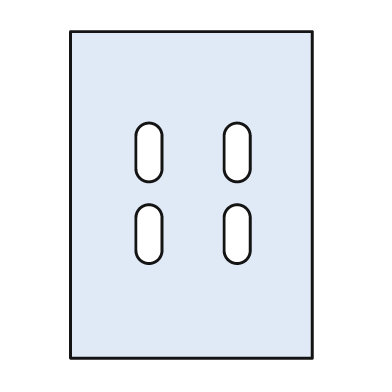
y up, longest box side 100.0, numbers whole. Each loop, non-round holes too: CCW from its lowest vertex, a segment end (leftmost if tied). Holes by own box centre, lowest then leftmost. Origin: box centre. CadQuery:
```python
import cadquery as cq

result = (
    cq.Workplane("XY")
    .moveTo(-37.0, -50.0)
    .lineTo(37.0, -50.0)
    .lineTo(37.0, 50.0)
    .lineTo(-37.0, 50.0)
    .close()
    .moveTo(-17.0, -17.0)
    .threePointArc((-13.0, -21.0), (-9.0, -17.0))
    .lineTo(-9.0, -7.0)
    .threePointArc((-13.0, -3.0), (-17.0, -7.0))
    .close()
    .moveTo(10.0, -17.0)
    .threePointArc((14.0, -21.0), (18.0, -17.0))
    .lineTo(18.0, -7.0)
    .threePointArc((14.0, -3.0), (10.0, -7.0))
    .close()
    .moveTo(-17.0, 8.0)
    .threePointArc((-13.0, 4.0), (-9.0, 8.0))
    .lineTo(-9.0, 18.0)
    .threePointArc((-13.0, 22.0), (-17.0, 18.0))
    .close()
    .moveTo(10.0, 8.0)
    .threePointArc((14.0, 4.0), (18.0, 8.0))
    .lineTo(18.0, 18.0)
    .threePointArc((14.0, 22.0), (10.0, 18.0))
    .close()
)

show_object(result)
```